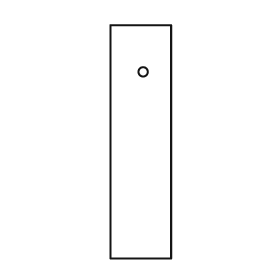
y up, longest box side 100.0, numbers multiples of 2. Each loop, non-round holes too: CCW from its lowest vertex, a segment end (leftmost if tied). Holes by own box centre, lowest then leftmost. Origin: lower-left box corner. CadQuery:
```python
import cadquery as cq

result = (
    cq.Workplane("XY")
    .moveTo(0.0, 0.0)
    .lineTo(26.0, 0.0)
    .lineTo(26.0, 100.0)
    .lineTo(0.0, 100.0)
    .close()
    .moveTo(14.0, 80.0)
    .circle(2.0)
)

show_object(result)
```